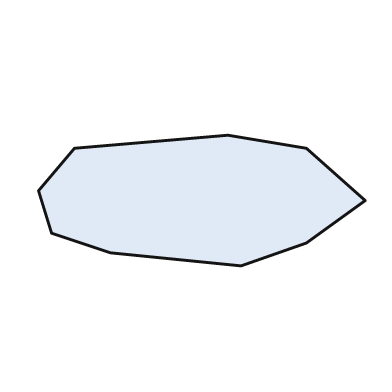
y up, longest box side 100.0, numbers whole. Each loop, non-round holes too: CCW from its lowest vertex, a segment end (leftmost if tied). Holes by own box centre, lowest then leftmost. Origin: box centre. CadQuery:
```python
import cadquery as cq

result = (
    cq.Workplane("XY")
    .moveTo(12.0, -20.0)
    .lineTo(32.0, -13.0)
    .lineTo(50.0, 0.0)
    .lineTo(32.0, 16.0)
    .lineTo(8.0, 20.0)
    .lineTo(-39.0, 16.0)
    .lineTo(-50.0, 3.0)
    .lineTo(-46.0, -10.0)
    .lineTo(-28.0, -16.0)
    .close()
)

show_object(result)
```